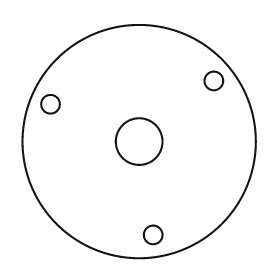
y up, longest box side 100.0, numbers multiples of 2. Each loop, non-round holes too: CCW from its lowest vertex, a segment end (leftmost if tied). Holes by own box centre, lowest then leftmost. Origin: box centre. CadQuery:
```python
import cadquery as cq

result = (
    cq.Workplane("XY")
    .moveTo(0.0, 0.0)
    .circle(50.0)
    .moveTo(6.0, -40.0)
    .circle(4.0)
    .moveTo(0.0, 0.0)
    .circle(10.0)
    .moveTo(-38.0, 16.0)
    .circle(4.0)
    .moveTo(32.0, 26.0)
    .circle(4.0)
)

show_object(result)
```